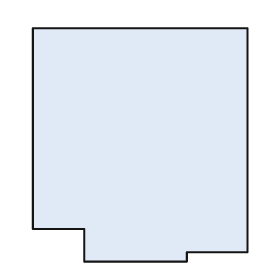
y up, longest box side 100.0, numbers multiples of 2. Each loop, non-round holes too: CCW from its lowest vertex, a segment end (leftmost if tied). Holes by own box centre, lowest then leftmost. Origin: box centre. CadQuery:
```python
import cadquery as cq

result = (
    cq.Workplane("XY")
    .moveTo(-24.0, -50.0)
    .lineTo(20.0, -50.0)
    .lineTo(20.0, -46.0)
    .lineTo(46.0, -46.0)
    .lineTo(46.0, 50.0)
    .lineTo(-46.0, 50.0)
    .lineTo(-46.0, -36.0)
    .lineTo(-24.0, -36.0)
    .close()
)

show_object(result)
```